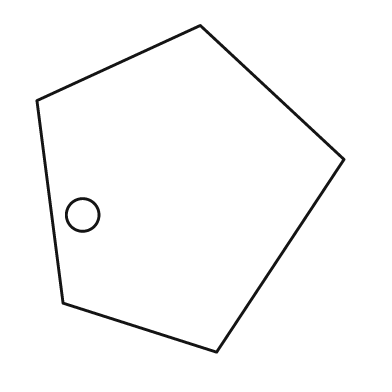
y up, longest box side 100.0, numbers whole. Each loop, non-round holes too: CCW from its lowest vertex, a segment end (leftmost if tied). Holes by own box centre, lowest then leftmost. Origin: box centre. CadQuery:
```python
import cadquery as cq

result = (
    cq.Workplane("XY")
    .moveTo(8.0, -50.0)
    .lineTo(47.0, 9.0)
    .lineTo(3.0, 50.0)
    .lineTo(-47.0, 27.0)
    .lineTo(-39.0, -35.0)
    .close()
    .moveTo(-33.0, -8.0)
    .circle(5.0)
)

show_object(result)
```